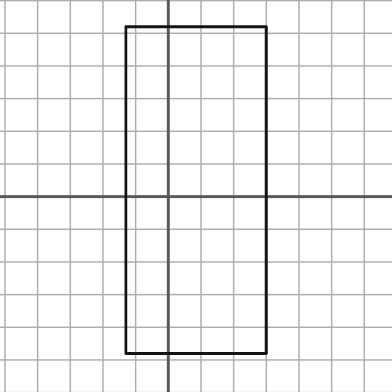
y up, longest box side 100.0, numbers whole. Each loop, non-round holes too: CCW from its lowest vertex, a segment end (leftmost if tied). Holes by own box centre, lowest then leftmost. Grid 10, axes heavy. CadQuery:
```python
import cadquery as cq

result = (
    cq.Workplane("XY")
    .moveTo(-13.0, -48.0)
    .lineTo(30.0, -48.0)
    .lineTo(30.0, 52.0)
    .lineTo(-13.0, 52.0)
    .close()
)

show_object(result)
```